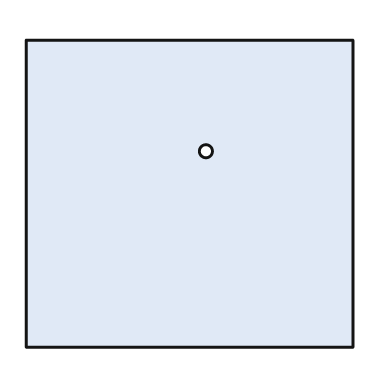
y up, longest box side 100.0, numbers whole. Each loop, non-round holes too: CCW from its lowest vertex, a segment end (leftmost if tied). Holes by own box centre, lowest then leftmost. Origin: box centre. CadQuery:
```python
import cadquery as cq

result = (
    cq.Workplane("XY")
    .moveTo(-50.0, -47.0)
    .lineTo(50.0, -47.0)
    .lineTo(50.0, 47.0)
    .lineTo(-50.0, 47.0)
    .close()
    .moveTo(5.0, 13.0)
    .circle(2.0)
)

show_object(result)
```